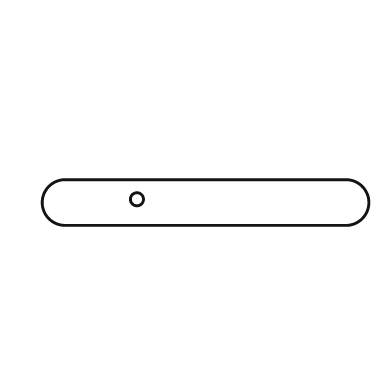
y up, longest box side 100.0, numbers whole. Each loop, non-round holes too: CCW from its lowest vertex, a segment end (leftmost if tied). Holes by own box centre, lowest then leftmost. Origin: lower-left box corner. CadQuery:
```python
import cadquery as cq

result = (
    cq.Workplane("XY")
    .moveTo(7.0, 0.0)
    .lineTo(93.0, 0.0)
    .threePointArc((100.0, 7.0), (93.0, 14.0))
    .lineTo(7.0, 14.0)
    .threePointArc((0.0, 7.0), (7.0, 0.0))
    .close()
    .moveTo(29.0, 8.0)
    .circle(2.0)
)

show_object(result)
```